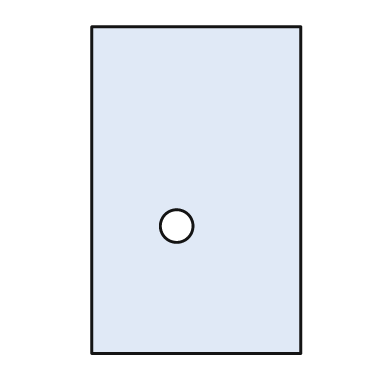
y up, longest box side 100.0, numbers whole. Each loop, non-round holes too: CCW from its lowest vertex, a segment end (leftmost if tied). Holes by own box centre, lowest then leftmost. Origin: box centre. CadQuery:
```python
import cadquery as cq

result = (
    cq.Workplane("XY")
    .moveTo(-32.0, -50.0)
    .lineTo(32.0, -50.0)
    .lineTo(32.0, 50.0)
    .lineTo(-32.0, 50.0)
    .close()
    .moveTo(-6.0, -11.0)
    .circle(5.0)
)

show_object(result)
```